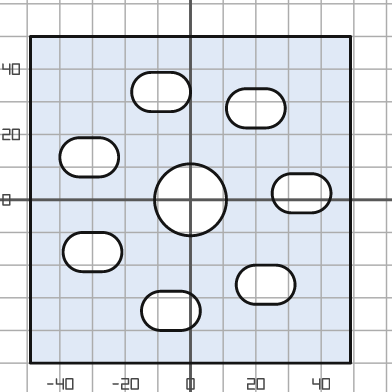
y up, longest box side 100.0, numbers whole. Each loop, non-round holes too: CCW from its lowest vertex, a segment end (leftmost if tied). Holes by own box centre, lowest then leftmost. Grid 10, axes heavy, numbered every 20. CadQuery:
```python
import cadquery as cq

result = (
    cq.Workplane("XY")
    .moveTo(-49.0, -50.0)
    .lineTo(49.0, -50.0)
    .lineTo(49.0, 50.0)
    .lineTo(-49.0, 50.0)
    .close()
    .moveTo(-9.0, -40.0)
    .lineTo(-3.0, -40.0)
    .threePointArc((3.0, -34.0), (-3.0, -28.0))
    .lineTo(-9.0, -28.0)
    .threePointArc((-15.0, -34.0), (-9.0, -40.0))
    .close()
    .moveTo(20.0, -32.0)
    .lineTo(26.0, -32.0)
    .threePointArc((32.0, -26.0), (26.0, -20.0))
    .lineTo(20.0, -20.0)
    .threePointArc((14.0, -26.0), (20.0, -32.0))
    .close()
    .moveTo(-33.0, -22.0)
    .lineTo(-27.0, -22.0)
    .threePointArc((-21.0, -16.0), (-27.0, -10.0))
    .lineTo(-33.0, -10.0)
    .threePointArc((-39.0, -16.0), (-33.0, -22.0))
    .close()
    .moveTo(0.0, 0.0)
    .circle(11.0)
    .moveTo(31.0, -4.0)
    .lineTo(37.0, -4.0)
    .threePointArc((43.0, 2.0), (37.0, 8.0))
    .lineTo(31.0, 8.0)
    .threePointArc((25.0, 2.0), (31.0, -4.0))
    .close()
    .moveTo(-34.0, 7.0)
    .lineTo(-28.0, 7.0)
    .threePointArc((-22.0, 13.0), (-28.0, 19.0))
    .lineTo(-34.0, 19.0)
    .threePointArc((-40.0, 13.0), (-34.0, 7.0))
    .close()
    .moveTo(17.0, 22.0)
    .lineTo(23.0, 22.0)
    .threePointArc((29.0, 28.0), (23.0, 34.0))
    .lineTo(17.0, 34.0)
    .threePointArc((11.0, 28.0), (17.0, 22.0))
    .close()
    .moveTo(-12.0, 27.0)
    .lineTo(-6.0, 27.0)
    .threePointArc((0.0, 33.0), (-6.0, 39.0))
    .lineTo(-12.0, 39.0)
    .threePointArc((-18.0, 33.0), (-12.0, 27.0))
    .close()
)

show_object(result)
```